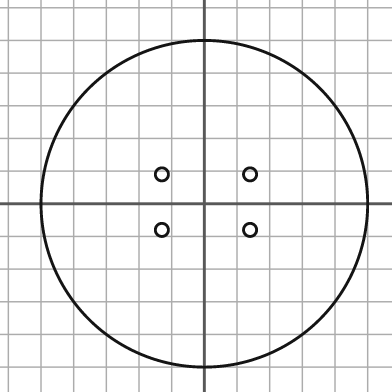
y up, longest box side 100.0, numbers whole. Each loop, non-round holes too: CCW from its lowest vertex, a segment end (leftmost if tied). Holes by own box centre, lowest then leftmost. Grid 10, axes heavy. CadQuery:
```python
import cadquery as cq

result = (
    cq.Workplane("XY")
    .moveTo(0.0, 0.0)
    .circle(50.0)
    .moveTo(-13.0, -8.0)
    .circle(2.0)
    .moveTo(14.0, -8.0)
    .circle(2.0)
    .moveTo(-13.0, 9.0)
    .circle(2.0)
    .moveTo(14.0, 9.0)
    .circle(2.0)
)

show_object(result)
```